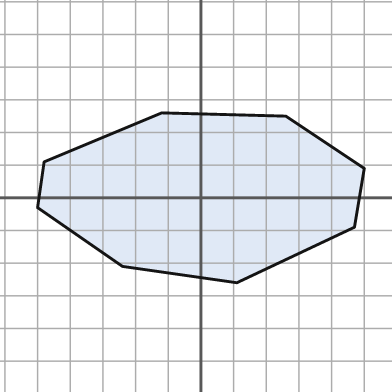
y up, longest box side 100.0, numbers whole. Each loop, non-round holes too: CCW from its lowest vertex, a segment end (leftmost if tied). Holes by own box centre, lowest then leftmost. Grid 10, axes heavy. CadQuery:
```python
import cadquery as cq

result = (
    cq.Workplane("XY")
    .moveTo(11.0, -26.0)
    .lineTo(47.0, -9.0)
    .lineTo(50.0, 9.0)
    .lineTo(26.0, 25.0)
    .lineTo(-12.0, 26.0)
    .lineTo(-48.0, 11.0)
    .lineTo(-50.0, -3.0)
    .lineTo(-24.0, -21.0)
    .close()
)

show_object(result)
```